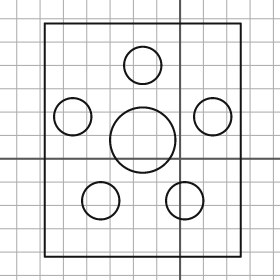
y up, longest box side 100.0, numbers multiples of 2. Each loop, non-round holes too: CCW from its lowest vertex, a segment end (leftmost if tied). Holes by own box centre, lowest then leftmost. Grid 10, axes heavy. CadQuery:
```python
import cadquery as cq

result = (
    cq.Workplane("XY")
    .moveTo(-58.0, -42.0)
    .lineTo(26.0, -42.0)
    .lineTo(26.0, 58.0)
    .lineTo(-58.0, 58.0)
    .close()
    .moveTo(-34.0, -18.0)
    .circle(8.0)
    .moveTo(2.0, -18.0)
    .circle(8.0)
    .moveTo(-16.0, 8.0)
    .circle(14.0)
    .moveTo(-46.0, 18.0)
    .circle(8.0)
    .moveTo(14.0, 18.0)
    .circle(8.0)
    .moveTo(-16.0, 40.0)
    .circle(8.0)
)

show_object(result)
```